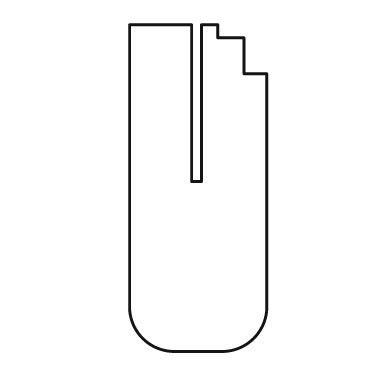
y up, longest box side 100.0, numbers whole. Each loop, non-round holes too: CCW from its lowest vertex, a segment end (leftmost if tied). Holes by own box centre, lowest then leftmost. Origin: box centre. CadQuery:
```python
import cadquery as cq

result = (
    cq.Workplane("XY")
    .moveTo(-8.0, -50.0)
    .lineTo(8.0, -50.0)
    .threePointArc((17.0, -46.0), (21.0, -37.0))
    .lineTo(21.0, 35.0)
    .lineTo(14.0, 35.0)
    .lineTo(14.0, 46.0)
    .lineTo(6.0, 46.0)
    .lineTo(6.0, 50.0)
    .lineTo(1.0, 50.0)
    .lineTo(1.0, 2.0)
    .lineTo(-2.0, 2.0)
    .lineTo(-2.0, 50.0)
    .lineTo(-21.0, 50.0)
    .lineTo(-21.0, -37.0)
    .threePointArc((-17.0, -46.0), (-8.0, -50.0))
    .close()
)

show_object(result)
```